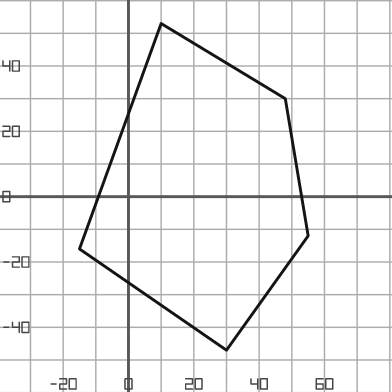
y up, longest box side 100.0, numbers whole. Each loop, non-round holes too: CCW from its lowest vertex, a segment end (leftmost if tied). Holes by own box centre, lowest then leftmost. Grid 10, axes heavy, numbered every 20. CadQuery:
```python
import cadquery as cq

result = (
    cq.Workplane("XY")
    .moveTo(30.0, -47.0)
    .lineTo(55.0, -12.0)
    .lineTo(48.0, 30.0)
    .lineTo(10.0, 53.0)
    .lineTo(-15.0, -16.0)
    .close()
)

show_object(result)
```